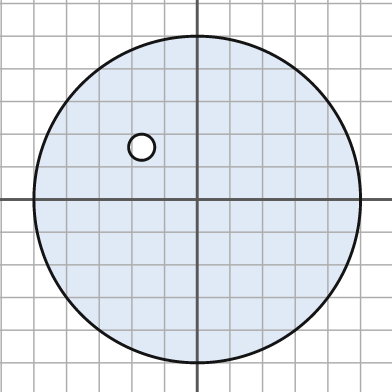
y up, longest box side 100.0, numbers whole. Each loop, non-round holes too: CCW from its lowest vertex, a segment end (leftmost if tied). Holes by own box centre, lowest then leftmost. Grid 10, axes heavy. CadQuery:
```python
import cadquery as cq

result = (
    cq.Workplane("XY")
    .moveTo(0.0, 0.0)
    .circle(50.0)
    .moveTo(-17.0, 16.0)
    .circle(4.0)
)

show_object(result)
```